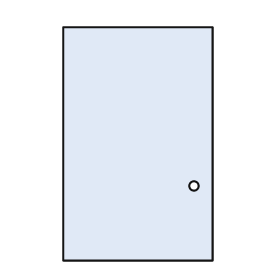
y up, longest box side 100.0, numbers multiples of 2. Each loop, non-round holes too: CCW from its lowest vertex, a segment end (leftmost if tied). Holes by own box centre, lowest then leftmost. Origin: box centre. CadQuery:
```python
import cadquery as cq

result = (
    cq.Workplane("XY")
    .moveTo(-32.0, -50.0)
    .lineTo(32.0, -50.0)
    .lineTo(32.0, 50.0)
    .lineTo(-32.0, 50.0)
    .close()
    .moveTo(24.0, -18.0)
    .circle(2.0)
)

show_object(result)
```